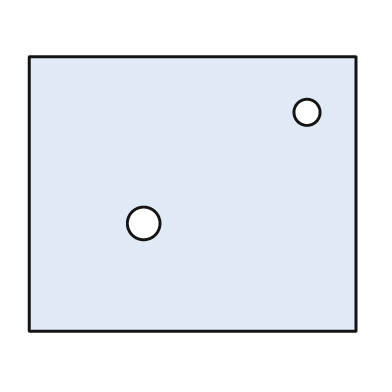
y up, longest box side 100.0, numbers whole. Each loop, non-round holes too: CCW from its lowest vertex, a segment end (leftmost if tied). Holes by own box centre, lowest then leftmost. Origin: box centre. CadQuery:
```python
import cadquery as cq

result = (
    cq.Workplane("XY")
    .moveTo(-50.0, -42.0)
    .lineTo(50.0, -42.0)
    .lineTo(50.0, 42.0)
    .lineTo(-50.0, 42.0)
    .close()
    .moveTo(-15.0, -9.0)
    .circle(5.0)
    .moveTo(35.0, 25.0)
    .circle(4.0)
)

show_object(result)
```